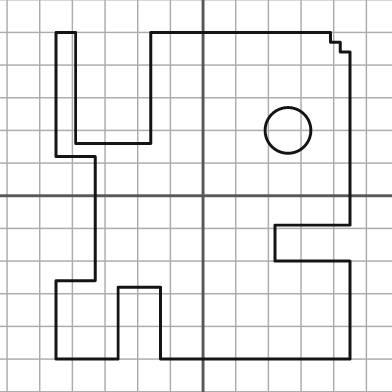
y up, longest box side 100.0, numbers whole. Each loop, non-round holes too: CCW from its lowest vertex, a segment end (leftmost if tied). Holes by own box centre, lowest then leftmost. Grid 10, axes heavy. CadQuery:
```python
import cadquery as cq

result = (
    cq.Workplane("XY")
    .moveTo(-45.0, -50.0)
    .lineTo(-26.0, -50.0)
    .lineTo(-26.0, -28.0)
    .lineTo(-13.0, -28.0)
    .lineTo(-13.0, -50.0)
    .lineTo(45.0, -50.0)
    .lineTo(45.0, -20.0)
    .lineTo(22.0, -20.0)
    .lineTo(22.0, -9.0)
    .lineTo(45.0, -9.0)
    .lineTo(45.0, 44.0)
    .lineTo(42.0, 44.0)
    .lineTo(42.0, 47.0)
    .lineTo(39.0, 47.0)
    .lineTo(39.0, 50.0)
    .lineTo(-16.0, 50.0)
    .lineTo(-16.0, 16.0)
    .lineTo(-39.0, 16.0)
    .lineTo(-39.0, 50.0)
    .lineTo(-45.0, 50.0)
    .lineTo(-45.0, 12.0)
    .lineTo(-33.0, 12.0)
    .lineTo(-33.0, -26.0)
    .lineTo(-45.0, -26.0)
    .close()
    .moveTo(26.0, 20.0)
    .circle(7.0)
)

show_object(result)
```